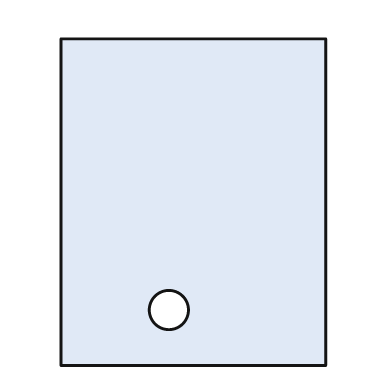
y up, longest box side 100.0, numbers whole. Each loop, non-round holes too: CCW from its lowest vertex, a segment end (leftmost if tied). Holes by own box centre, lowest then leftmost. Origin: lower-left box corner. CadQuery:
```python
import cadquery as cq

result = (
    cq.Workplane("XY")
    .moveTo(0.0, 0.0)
    .lineTo(81.0, 0.0)
    .lineTo(81.0, 100.0)
    .lineTo(0.0, 100.0)
    .close()
    .moveTo(33.0, 17.0)
    .circle(6.0)
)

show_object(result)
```